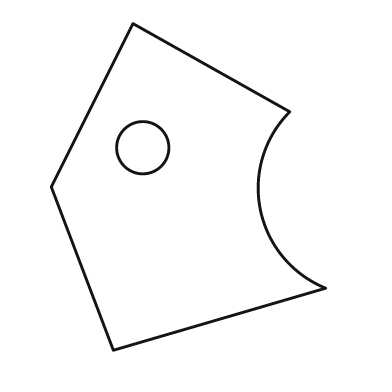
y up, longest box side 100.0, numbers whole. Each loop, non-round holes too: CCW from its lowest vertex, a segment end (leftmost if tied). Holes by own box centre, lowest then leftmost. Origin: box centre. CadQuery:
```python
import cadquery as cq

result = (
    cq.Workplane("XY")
    .moveTo(-23.0, -50.0)
    .lineTo(42.0, -31.0)
    .threePointArc((22.0, -7.0), (31.0, 23.0))
    .lineTo(-17.0, 50.0)
    .lineTo(-42.0, 0.0)
    .close()
    .moveTo(-14.0, 12.0)
    .circle(8.0)
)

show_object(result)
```